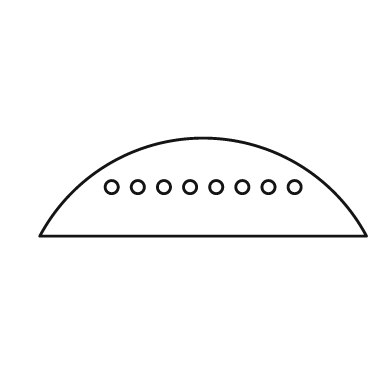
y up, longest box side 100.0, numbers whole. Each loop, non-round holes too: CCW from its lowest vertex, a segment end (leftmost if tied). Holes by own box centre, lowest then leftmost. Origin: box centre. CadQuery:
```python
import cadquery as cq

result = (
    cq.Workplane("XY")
    .moveTo(-50.0, -15.0)
    .lineTo(50.0, -15.0)
    .threePointArc((0.0, 15.0), (-50.0, -15.0))
    .close()
    .moveTo(-28.0, 0.0)
    .circle(2.0)
    .moveTo(-20.0, 0.0)
    .circle(2.0)
    .moveTo(-12.0, 0.0)
    .circle(2.0)
    .moveTo(-4.0, 0.0)
    .circle(2.0)
    .moveTo(4.0, 0.0)
    .circle(2.0)
    .moveTo(12.0, 0.0)
    .circle(2.0)
    .moveTo(20.0, 0.0)
    .circle(2.0)
    .moveTo(28.0, 0.0)
    .circle(2.0)
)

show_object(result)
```